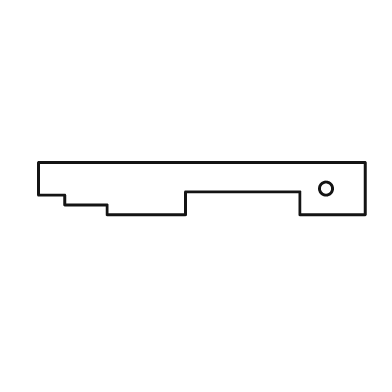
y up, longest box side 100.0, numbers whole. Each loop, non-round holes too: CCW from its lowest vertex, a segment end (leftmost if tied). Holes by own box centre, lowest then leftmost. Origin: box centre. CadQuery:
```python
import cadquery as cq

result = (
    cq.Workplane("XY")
    .moveTo(-29.0, -8.0)
    .lineTo(-5.0, -8.0)
    .lineTo(-5.0, -1.0)
    .lineTo(30.0, -1.0)
    .lineTo(30.0, -8.0)
    .lineTo(50.0, -8.0)
    .lineTo(50.0, 8.0)
    .lineTo(-50.0, 8.0)
    .lineTo(-50.0, -2.0)
    .lineTo(-42.0, -2.0)
    .lineTo(-42.0, -5.0)
    .lineTo(-29.0, -5.0)
    .close()
    .moveTo(38.0, 0.0)
    .circle(2.0)
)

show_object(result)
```